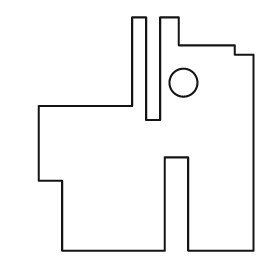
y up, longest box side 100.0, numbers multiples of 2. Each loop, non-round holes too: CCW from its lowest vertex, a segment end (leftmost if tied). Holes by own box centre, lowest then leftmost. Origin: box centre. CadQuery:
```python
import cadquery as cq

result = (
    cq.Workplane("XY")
    .moveTo(-36.0, -50.0)
    .lineTo(8.0, -50.0)
    .lineTo(8.0, -10.0)
    .lineTo(18.0, -10.0)
    .lineTo(18.0, -50.0)
    .lineTo(46.0, -50.0)
    .lineTo(46.0, 34.0)
    .lineTo(38.0, 34.0)
    .lineTo(38.0, 38.0)
    .lineTo(14.0, 38.0)
    .lineTo(14.0, 50.0)
    .lineTo(6.0, 50.0)
    .lineTo(6.0, 6.0)
    .lineTo(0.0, 6.0)
    .lineTo(0.0, 50.0)
    .lineTo(-6.0, 50.0)
    .lineTo(-6.0, 12.0)
    .lineTo(-46.0, 12.0)
    .lineTo(-46.0, -20.0)
    .lineTo(-36.0, -20.0)
    .close()
    .moveTo(16.0, 22.0)
    .circle(6.0)
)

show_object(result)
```